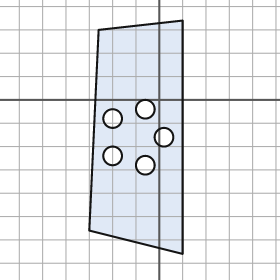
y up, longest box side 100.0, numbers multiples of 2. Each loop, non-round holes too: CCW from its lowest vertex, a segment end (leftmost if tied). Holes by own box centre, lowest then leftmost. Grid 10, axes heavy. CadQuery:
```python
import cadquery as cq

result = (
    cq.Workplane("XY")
    .moveTo(10.0, -66.0)
    .lineTo(10.0, 34.0)
    .lineTo(-26.0, 30.0)
    .lineTo(-30.0, -56.0)
    .close()
    .moveTo(-6.0, -28.0)
    .circle(4.0)
    .moveTo(-20.0, -24.0)
    .circle(4.0)
    .moveTo(2.0, -16.0)
    .circle(4.0)
    .moveTo(-20.0, -8.0)
    .circle(4.0)
    .moveTo(-6.0, -4.0)
    .circle(4.0)
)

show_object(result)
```